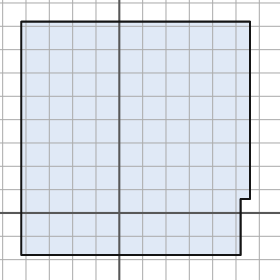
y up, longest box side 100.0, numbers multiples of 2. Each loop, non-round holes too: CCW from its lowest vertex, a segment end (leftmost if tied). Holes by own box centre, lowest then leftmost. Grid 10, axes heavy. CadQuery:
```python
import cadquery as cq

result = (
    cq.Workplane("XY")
    .moveTo(-42.0, -18.0)
    .lineTo(52.0, -18.0)
    .lineTo(52.0, 6.0)
    .lineTo(56.0, 6.0)
    .lineTo(56.0, 82.0)
    .lineTo(-42.0, 82.0)
    .close()
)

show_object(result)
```